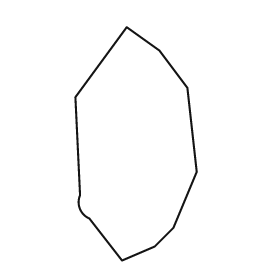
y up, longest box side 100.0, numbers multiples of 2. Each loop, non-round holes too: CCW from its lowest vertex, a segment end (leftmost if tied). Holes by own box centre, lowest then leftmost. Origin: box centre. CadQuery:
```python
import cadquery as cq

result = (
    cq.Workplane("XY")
    .moveTo(-6.0, -50.0)
    .lineTo(8.0, -44.0)
    .lineTo(16.0, -36.0)
    .lineTo(26.0, -12.0)
    .lineTo(22.0, 24.0)
    .lineTo(10.0, 40.0)
    .lineTo(-4.0, 50.0)
    .lineTo(-26.0, 20.0)
    .lineTo(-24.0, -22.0)
    .threePointArc((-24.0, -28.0), (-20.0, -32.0))
    .close()
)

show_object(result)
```